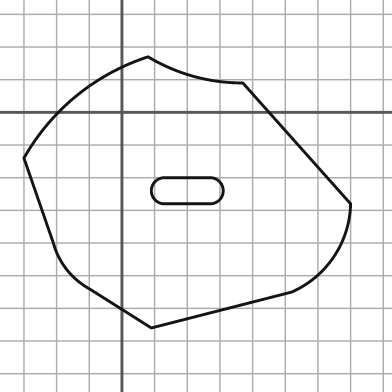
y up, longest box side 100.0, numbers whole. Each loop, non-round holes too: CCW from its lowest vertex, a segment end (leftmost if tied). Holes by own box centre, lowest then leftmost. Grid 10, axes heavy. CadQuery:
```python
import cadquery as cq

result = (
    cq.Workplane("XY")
    .moveTo(9.0, -66.0)
    .lineTo(52.0, -55.0)
    .threePointArc((65.0, -44.0), (70.0, -28.0))
    .lineTo(37.0, 9.0)
    .threePointArc((22.0, 11.0), (8.0, 17.0))
    .threePointArc((-14.0, 5.0), (-30.0, -14.0))
    .lineTo(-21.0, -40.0)
    .threePointArc((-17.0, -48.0), (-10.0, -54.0))
    .close()
    .moveTo(13.0, -28.0)
    .lineTo(27.0, -28.0)
    .threePointArc((31.0, -24.0), (27.0, -20.0))
    .lineTo(13.0, -20.0)
    .threePointArc((9.0, -24.0), (13.0, -28.0))
    .close()
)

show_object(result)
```